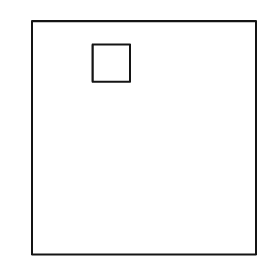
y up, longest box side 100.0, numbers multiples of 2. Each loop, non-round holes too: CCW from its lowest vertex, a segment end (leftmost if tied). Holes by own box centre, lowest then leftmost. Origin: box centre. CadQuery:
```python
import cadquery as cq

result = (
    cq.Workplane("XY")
    .moveTo(-48.0, -50.0)
    .lineTo(48.0, -50.0)
    .lineTo(48.0, 50.0)
    .lineTo(-48.0, 50.0)
    .close()
    .moveTo(-22.0, 24.0)
    .lineTo(-6.0, 24.0)
    .lineTo(-6.0, 40.0)
    .lineTo(-22.0, 40.0)
    .close()
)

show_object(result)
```